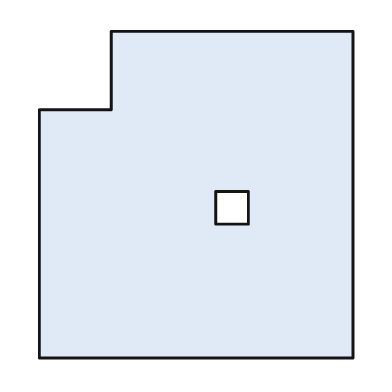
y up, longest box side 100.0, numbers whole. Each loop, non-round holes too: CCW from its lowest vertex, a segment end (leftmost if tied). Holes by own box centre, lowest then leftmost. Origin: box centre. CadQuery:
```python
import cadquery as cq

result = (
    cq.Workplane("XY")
    .moveTo(-48.0, -50.0)
    .lineTo(48.0, -50.0)
    .lineTo(48.0, 50.0)
    .lineTo(-26.0, 50.0)
    .lineTo(-26.0, 26.0)
    .lineTo(-48.0, 26.0)
    .close()
    .moveTo(6.0, -9.0)
    .lineTo(16.0, -9.0)
    .lineTo(16.0, 1.0)
    .lineTo(6.0, 1.0)
    .close()
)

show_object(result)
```